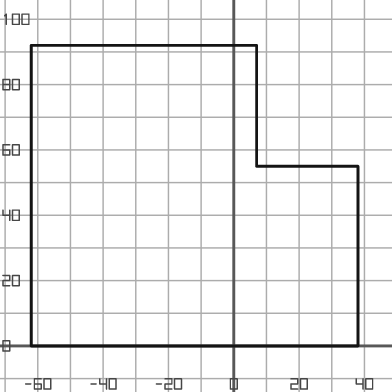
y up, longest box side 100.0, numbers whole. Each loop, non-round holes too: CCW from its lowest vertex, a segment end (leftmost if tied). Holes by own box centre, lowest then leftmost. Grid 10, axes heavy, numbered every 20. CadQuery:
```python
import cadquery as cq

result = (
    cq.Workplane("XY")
    .moveTo(-62.0, 0.0)
    .lineTo(38.0, 0.0)
    .lineTo(38.0, 55.0)
    .lineTo(7.0, 55.0)
    .lineTo(7.0, 92.0)
    .lineTo(-62.0, 92.0)
    .close()
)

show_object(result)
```